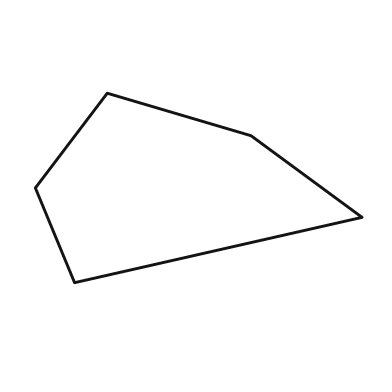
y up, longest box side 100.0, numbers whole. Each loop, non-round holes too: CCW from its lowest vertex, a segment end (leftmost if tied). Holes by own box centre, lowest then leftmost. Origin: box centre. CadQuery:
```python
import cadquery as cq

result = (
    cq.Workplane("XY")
    .moveTo(-38.0, -29.0)
    .lineTo(50.0, -9.0)
    .lineTo(16.0, 16.0)
    .lineTo(-28.0, 29.0)
    .lineTo(-50.0, 0.0)
    .close()
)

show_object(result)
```